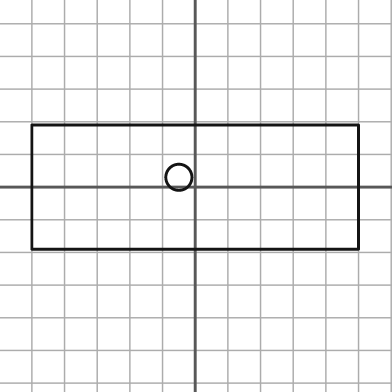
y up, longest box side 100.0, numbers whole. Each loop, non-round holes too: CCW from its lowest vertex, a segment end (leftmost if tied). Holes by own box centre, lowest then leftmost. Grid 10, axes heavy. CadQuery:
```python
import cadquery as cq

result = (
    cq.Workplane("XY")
    .moveTo(-50.0, -19.0)
    .lineTo(50.0, -19.0)
    .lineTo(50.0, 19.0)
    .lineTo(-50.0, 19.0)
    .close()
    .moveTo(-5.0, 3.0)
    .circle(4.0)
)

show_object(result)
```